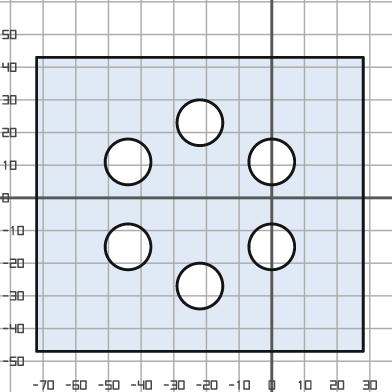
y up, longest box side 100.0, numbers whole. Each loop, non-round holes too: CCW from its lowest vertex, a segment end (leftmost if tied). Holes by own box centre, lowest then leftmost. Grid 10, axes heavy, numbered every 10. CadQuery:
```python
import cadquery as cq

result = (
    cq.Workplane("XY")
    .moveTo(-72.0, -47.0)
    .lineTo(28.0, -47.0)
    .lineTo(28.0, 43.0)
    .lineTo(-72.0, 43.0)
    .close()
    .moveTo(-22.0, -27.0)
    .circle(7.0)
    .moveTo(-44.0, -15.0)
    .circle(7.0)
    .moveTo(0.0, -15.0)
    .circle(7.0)
    .moveTo(-44.0, 11.0)
    .circle(7.0)
    .moveTo(0.0, 11.0)
    .circle(7.0)
    .moveTo(-22.0, 23.0)
    .circle(7.0)
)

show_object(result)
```